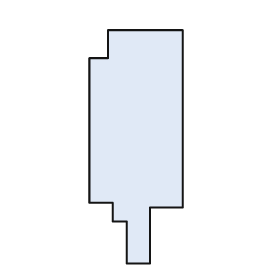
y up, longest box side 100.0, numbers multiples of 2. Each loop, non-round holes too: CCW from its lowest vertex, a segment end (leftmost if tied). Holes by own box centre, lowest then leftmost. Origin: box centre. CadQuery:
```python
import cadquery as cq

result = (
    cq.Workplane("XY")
    .moveTo(-4.0, -50.0)
    .lineTo(6.0, -50.0)
    .lineTo(6.0, -26.0)
    .lineTo(20.0, -26.0)
    .lineTo(20.0, 50.0)
    .lineTo(-12.0, 50.0)
    .lineTo(-12.0, 38.0)
    .lineTo(-20.0, 38.0)
    .lineTo(-20.0, -24.0)
    .lineTo(-10.0, -24.0)
    .lineTo(-10.0, -32.0)
    .lineTo(-4.0, -32.0)
    .close()
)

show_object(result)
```